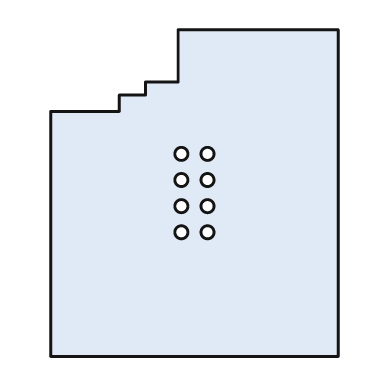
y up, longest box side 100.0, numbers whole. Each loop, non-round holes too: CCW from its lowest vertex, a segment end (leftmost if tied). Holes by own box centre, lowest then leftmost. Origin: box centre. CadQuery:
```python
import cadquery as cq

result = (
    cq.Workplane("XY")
    .moveTo(-44.0, -50.0)
    .lineTo(44.0, -50.0)
    .lineTo(44.0, 50.0)
    .lineTo(-5.0, 50.0)
    .lineTo(-5.0, 34.0)
    .lineTo(-15.0, 34.0)
    .lineTo(-15.0, 30.0)
    .lineTo(-23.0, 30.0)
    .lineTo(-23.0, 25.0)
    .lineTo(-44.0, 25.0)
    .close()
    .moveTo(-4.0, -12.0)
    .circle(2.0)
    .moveTo(4.0, -12.0)
    .circle(2.0)
    .moveTo(-4.0, -4.0)
    .circle(2.0)
    .moveTo(4.0, -4.0)
    .circle(2.0)
    .moveTo(-4.0, 4.0)
    .circle(2.0)
    .moveTo(4.0, 4.0)
    .circle(2.0)
    .moveTo(-4.0, 12.0)
    .circle(2.0)
    .moveTo(4.0, 12.0)
    .circle(2.0)
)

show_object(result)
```